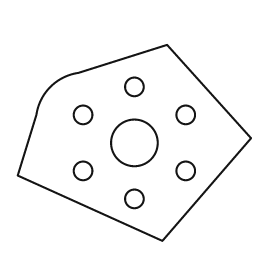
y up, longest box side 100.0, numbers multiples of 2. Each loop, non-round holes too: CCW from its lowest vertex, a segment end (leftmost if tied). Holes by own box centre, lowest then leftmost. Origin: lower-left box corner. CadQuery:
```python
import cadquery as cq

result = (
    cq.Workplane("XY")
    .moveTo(62.0, 0.0)
    .lineTo(100.0, 44.0)
    .lineTo(64.0, 84.0)
    .lineTo(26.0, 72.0)
    .threePointArc((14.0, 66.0), (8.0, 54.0))
    .lineTo(0.0, 28.0)
    .close()
    .moveTo(50.0, 18.0)
    .circle(4.0)
    .moveTo(28.0, 30.0)
    .circle(4.0)
    .moveTo(72.0, 30.0)
    .circle(4.0)
    .moveTo(50.0, 42.0)
    .circle(10.0)
    .moveTo(28.0, 54.0)
    .circle(4.0)
    .moveTo(72.0, 54.0)
    .circle(4.0)
    .moveTo(50.0, 66.0)
    .circle(4.0)
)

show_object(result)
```